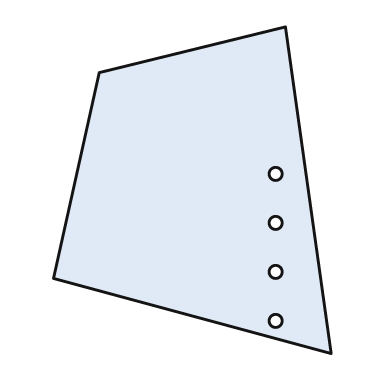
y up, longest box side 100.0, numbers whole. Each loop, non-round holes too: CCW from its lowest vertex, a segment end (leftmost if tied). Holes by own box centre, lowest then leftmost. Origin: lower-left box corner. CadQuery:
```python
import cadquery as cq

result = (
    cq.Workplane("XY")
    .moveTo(85.0, 0.0)
    .lineTo(71.0, 100.0)
    .lineTo(14.0, 86.0)
    .lineTo(0.0, 23.0)
    .close()
    .moveTo(68.0, 10.0)
    .circle(2.0)
    .moveTo(68.0, 25.0)
    .circle(2.0)
    .moveTo(68.0, 40.0)
    .circle(2.0)
    .moveTo(68.0, 55.0)
    .circle(2.0)
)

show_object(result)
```